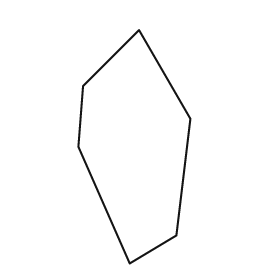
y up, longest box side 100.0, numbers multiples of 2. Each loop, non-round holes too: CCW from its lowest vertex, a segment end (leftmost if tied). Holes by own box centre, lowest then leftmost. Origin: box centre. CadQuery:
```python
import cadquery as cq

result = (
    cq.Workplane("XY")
    .moveTo(-2.0, -50.0)
    .lineTo(18.0, -38.0)
    .lineTo(24.0, 12.0)
    .lineTo(2.0, 50.0)
    .lineTo(-22.0, 26.0)
    .lineTo(-24.0, 0.0)
    .close()
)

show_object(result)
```